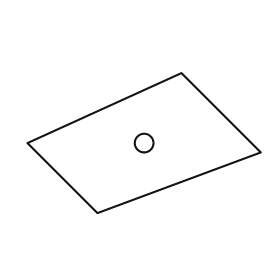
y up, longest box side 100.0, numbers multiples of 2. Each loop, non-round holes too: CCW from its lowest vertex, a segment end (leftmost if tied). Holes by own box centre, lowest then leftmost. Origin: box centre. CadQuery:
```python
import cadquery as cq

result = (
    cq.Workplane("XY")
    .moveTo(-20.0, -30.0)
    .lineTo(50.0, -4.0)
    .lineTo(16.0, 30.0)
    .lineTo(-50.0, 0.0)
    .close()
    .moveTo(0.0, 0.0)
    .circle(4.0)
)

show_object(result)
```